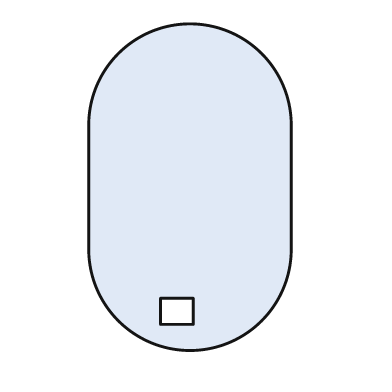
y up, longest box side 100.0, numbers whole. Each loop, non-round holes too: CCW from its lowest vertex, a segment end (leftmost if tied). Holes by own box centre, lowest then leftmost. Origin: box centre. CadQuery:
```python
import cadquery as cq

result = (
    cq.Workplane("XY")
    .moveTo(-31.0, -19.0)
    .threePointArc((0.0, -50.0), (31.0, -19.0))
    .lineTo(31.0, 19.0)
    .threePointArc((0.0, 50.0), (-31.0, 19.0))
    .close()
    .moveTo(-9.0, -42.0)
    .lineTo(1.0, -42.0)
    .lineTo(1.0, -34.0)
    .lineTo(-9.0, -34.0)
    .close()
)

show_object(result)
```